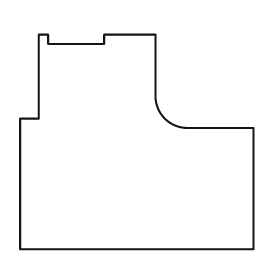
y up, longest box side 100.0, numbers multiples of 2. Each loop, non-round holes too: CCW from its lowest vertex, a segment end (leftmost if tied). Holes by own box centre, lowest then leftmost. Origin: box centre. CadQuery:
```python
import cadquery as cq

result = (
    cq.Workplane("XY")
    .moveTo(-50.0, -46.0)
    .lineTo(50.0, -46.0)
    .lineTo(50.0, 6.0)
    .lineTo(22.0, 6.0)
    .threePointArc((12.0, 10.0), (8.0, 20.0))
    .lineTo(8.0, 46.0)
    .lineTo(-14.0, 46.0)
    .lineTo(-14.0, 42.0)
    .lineTo(-38.0, 42.0)
    .lineTo(-38.0, 46.0)
    .lineTo(-42.0, 46.0)
    .lineTo(-42.0, 10.0)
    .lineTo(-50.0, 10.0)
    .close()
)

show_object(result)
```